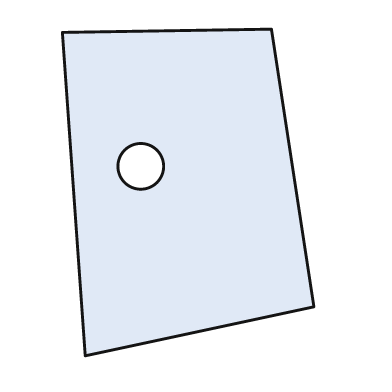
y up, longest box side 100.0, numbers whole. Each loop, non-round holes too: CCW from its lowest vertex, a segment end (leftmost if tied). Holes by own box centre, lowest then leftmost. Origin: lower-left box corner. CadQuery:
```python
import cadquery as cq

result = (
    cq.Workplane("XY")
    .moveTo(7.0, 0.0)
    .lineTo(77.0, 15.0)
    .lineTo(64.0, 100.0)
    .lineTo(0.0, 99.0)
    .close()
    .moveTo(24.0, 58.0)
    .circle(7.0)
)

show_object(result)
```